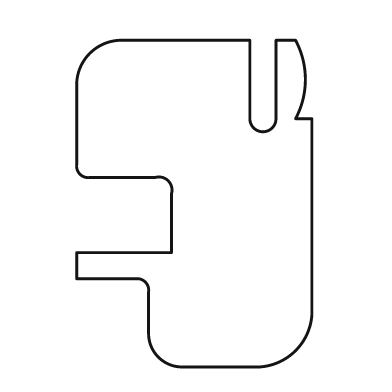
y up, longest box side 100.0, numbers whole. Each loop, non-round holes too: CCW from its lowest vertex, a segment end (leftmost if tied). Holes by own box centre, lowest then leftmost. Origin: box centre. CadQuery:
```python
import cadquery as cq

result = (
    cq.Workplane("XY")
    .moveTo(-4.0, -50.0)
    .lineTo(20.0, -50.0)
    .threePointArc((31.0, -45.0), (36.0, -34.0))
    .lineTo(36.0, 26.0)
    .lineTo(31.0, 26.0)
    .threePointArc((34.0, 38.0), (31.0, 50.0))
    .lineTo(25.0, 50.0)
    .lineTo(25.0, 26.0)
    .threePointArc((21.0, 22.0), (17.0, 26.0))
    .lineTo(17.0, 50.0)
    .lineTo(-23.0, 50.0)
    .threePointArc((-32.0, 46.0), (-36.0, 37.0))
    .lineTo(-36.0, 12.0)
    .threePointArc((-35.0, 9.0), (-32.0, 8.0))
    .lineTo(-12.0, 8.0)
    .threePointArc((-8.0, 7.0), (-7.0, 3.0))
    .lineTo(-7.0, -15.0)
    .lineTo(-36.0, -15.0)
    .lineTo(-36.0, -23.0)
    .lineTo(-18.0, -23.0)
    .threePointArc((-15.0, -24.0), (-14.0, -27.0))
    .lineTo(-14.0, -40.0)
    .threePointArc((-11.0, -47.0), (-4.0, -50.0))
    .close()
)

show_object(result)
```